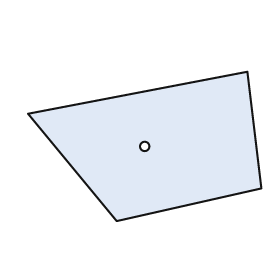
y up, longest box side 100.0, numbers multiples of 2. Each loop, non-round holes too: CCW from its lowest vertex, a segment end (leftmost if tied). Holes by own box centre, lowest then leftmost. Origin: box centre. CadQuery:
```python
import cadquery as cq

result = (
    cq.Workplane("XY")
    .moveTo(-12.0, -32.0)
    .lineTo(50.0, -18.0)
    .lineTo(44.0, 32.0)
    .lineTo(-50.0, 14.0)
    .close()
    .moveTo(0.0, 0.0)
    .circle(2.0)
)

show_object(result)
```